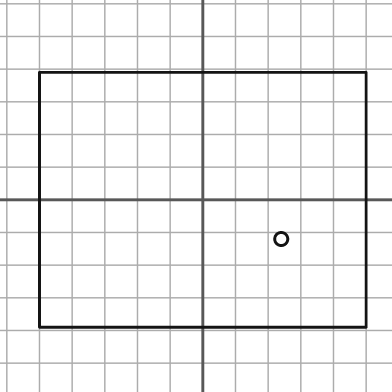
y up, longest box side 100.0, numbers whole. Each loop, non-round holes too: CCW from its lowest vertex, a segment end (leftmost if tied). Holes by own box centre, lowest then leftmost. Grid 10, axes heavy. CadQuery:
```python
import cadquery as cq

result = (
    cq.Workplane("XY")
    .moveTo(-50.0, -39.0)
    .lineTo(50.0, -39.0)
    .lineTo(50.0, 39.0)
    .lineTo(-50.0, 39.0)
    .close()
    .moveTo(24.0, -12.0)
    .circle(2.0)
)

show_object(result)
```